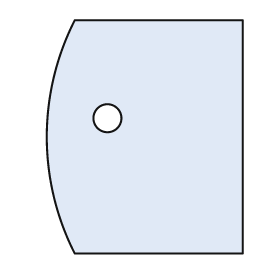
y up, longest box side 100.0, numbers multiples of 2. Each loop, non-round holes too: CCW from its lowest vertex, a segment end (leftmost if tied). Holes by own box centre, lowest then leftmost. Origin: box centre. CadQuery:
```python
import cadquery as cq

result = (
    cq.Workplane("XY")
    .moveTo(-30.0, -50.0)
    .lineTo(42.0, -50.0)
    .lineTo(42.0, 50.0)
    .lineTo(-30.0, 50.0)
    .threePointArc((-42.0, 0.0), (-30.0, -50.0))
    .close()
    .moveTo(-16.0, 8.0)
    .circle(6.0)
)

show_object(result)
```